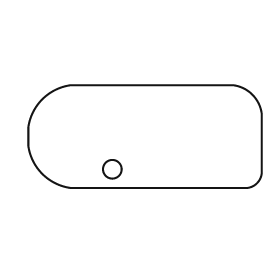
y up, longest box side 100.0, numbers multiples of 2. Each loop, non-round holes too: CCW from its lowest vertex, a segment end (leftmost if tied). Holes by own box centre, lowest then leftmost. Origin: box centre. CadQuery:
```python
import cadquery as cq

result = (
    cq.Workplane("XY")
    .moveTo(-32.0, -22.0)
    .lineTo(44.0, -22.0)
    .threePointArc((48.0, -20.0), (50.0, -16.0))
    .lineTo(50.0, 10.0)
    .threePointArc((46.0, 18.0), (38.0, 22.0))
    .lineTo(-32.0, 22.0)
    .threePointArc((-44.0, 16.0), (-50.0, 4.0))
    .lineTo(-50.0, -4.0)
    .threePointArc((-44.0, -16.0), (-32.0, -22.0))
    .close()
    .moveTo(-14.0, -14.0)
    .circle(4.0)
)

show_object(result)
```